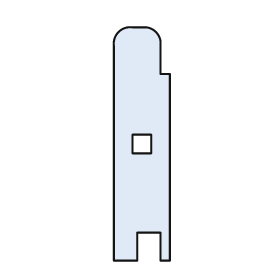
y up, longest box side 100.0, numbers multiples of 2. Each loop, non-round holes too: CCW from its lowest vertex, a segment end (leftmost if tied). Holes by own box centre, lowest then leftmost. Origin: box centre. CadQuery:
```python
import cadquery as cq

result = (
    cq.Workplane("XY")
    .moveTo(-12.0, -50.0)
    .lineTo(-2.0, -50.0)
    .lineTo(-2.0, -38.0)
    .lineTo(8.0, -38.0)
    .lineTo(8.0, -50.0)
    .lineTo(12.0, -50.0)
    .lineTo(12.0, 30.0)
    .lineTo(8.0, 30.0)
    .lineTo(8.0, 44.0)
    .threePointArc((6.0, 48.0), (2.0, 50.0))
    .lineTo(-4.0, 50.0)
    .threePointArc((-10.0, 48.0), (-12.0, 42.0))
    .close()
    .moveTo(-4.0, -4.0)
    .lineTo(4.0, -4.0)
    .lineTo(4.0, 4.0)
    .lineTo(-4.0, 4.0)
    .close()
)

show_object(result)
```